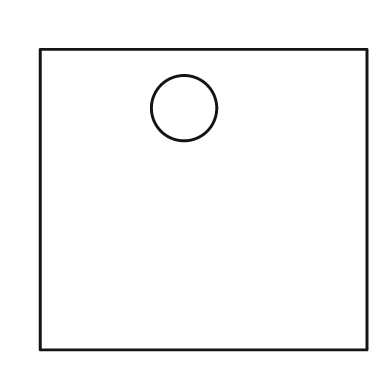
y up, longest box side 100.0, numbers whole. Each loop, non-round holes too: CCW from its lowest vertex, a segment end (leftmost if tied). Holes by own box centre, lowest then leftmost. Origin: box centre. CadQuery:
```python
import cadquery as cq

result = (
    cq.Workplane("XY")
    .moveTo(-50.0, -46.0)
    .lineTo(50.0, -46.0)
    .lineTo(50.0, 46.0)
    .lineTo(-50.0, 46.0)
    .close()
    .moveTo(-6.0, 28.0)
    .circle(10.0)
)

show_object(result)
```